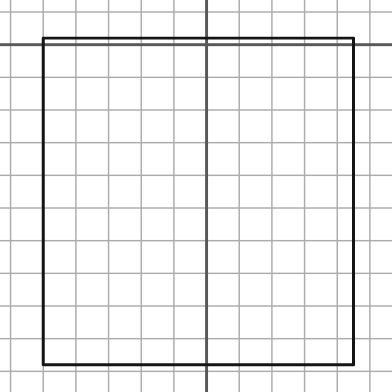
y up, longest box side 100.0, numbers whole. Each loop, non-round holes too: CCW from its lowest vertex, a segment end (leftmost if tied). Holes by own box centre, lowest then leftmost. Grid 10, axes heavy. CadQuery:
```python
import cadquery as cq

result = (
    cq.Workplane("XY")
    .moveTo(-50.0, -98.0)
    .lineTo(45.0, -98.0)
    .lineTo(45.0, 2.0)
    .lineTo(-50.0, 2.0)
    .close()
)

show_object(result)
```